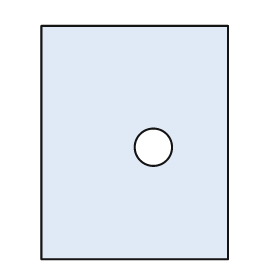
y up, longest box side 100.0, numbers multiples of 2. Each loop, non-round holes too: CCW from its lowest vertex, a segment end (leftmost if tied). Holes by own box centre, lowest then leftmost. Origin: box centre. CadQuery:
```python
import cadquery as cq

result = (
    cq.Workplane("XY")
    .moveTo(-40.0, -50.0)
    .lineTo(40.0, -50.0)
    .lineTo(40.0, 50.0)
    .lineTo(-40.0, 50.0)
    .close()
    .moveTo(8.0, -2.0)
    .circle(8.0)
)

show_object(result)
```